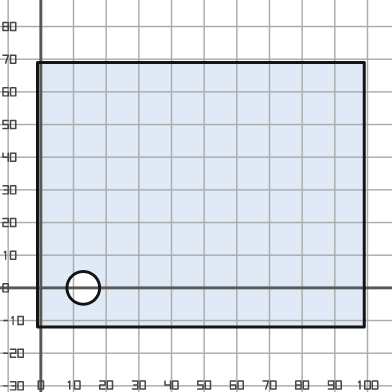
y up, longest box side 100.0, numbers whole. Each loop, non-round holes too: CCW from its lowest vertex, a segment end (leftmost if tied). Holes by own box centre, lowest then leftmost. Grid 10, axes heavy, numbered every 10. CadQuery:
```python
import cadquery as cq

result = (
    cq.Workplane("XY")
    .moveTo(-1.0, -12.0)
    .lineTo(99.0, -12.0)
    .lineTo(99.0, 69.0)
    .lineTo(-1.0, 69.0)
    .close()
    .moveTo(13.0, 0.0)
    .circle(5.0)
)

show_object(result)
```